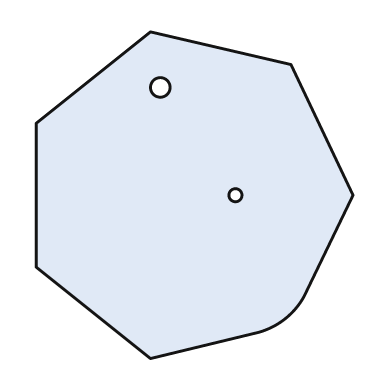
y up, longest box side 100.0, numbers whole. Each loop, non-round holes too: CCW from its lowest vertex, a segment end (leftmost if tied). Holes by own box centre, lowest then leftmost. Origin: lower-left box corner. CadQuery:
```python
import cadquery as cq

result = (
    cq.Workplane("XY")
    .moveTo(35.0, 0.0)
    .lineTo(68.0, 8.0)
    .threePointArc((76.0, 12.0), (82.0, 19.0))
    .lineTo(97.0, 50.0)
    .lineTo(78.0, 90.0)
    .lineTo(35.0, 100.0)
    .lineTo(0.0, 72.0)
    .lineTo(0.0, 28.0)
    .close()
    .moveTo(61.0, 50.0)
    .circle(2.0)
    .moveTo(38.0, 83.0)
    .circle(3.0)
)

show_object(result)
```